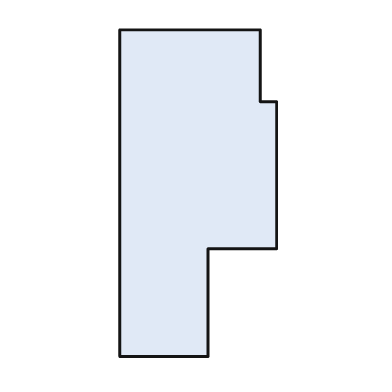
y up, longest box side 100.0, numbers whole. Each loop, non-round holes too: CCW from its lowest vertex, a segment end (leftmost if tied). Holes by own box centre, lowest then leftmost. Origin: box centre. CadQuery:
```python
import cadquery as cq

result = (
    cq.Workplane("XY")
    .moveTo(-24.0, -50.0)
    .lineTo(3.0, -50.0)
    .lineTo(3.0, -17.0)
    .lineTo(24.0, -17.0)
    .lineTo(24.0, 28.0)
    .lineTo(19.0, 28.0)
    .lineTo(19.0, 50.0)
    .lineTo(-24.0, 50.0)
    .close()
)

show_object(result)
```